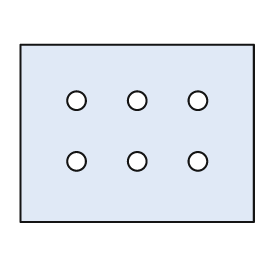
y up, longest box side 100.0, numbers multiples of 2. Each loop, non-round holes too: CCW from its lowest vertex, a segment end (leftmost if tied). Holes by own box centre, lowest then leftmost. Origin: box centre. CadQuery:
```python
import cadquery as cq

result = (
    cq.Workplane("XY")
    .moveTo(-50.0, -38.0)
    .lineTo(50.0, -38.0)
    .lineTo(50.0, 38.0)
    .lineTo(-50.0, 38.0)
    .close()
    .moveTo(-26.0, -12.0)
    .circle(4.0)
    .moveTo(0.0, -12.0)
    .circle(4.0)
    .moveTo(26.0, -12.0)
    .circle(4.0)
    .moveTo(-26.0, 14.0)
    .circle(4.0)
    .moveTo(0.0, 14.0)
    .circle(4.0)
    .moveTo(26.0, 14.0)
    .circle(4.0)
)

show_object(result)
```